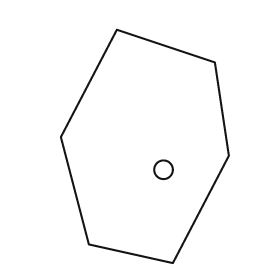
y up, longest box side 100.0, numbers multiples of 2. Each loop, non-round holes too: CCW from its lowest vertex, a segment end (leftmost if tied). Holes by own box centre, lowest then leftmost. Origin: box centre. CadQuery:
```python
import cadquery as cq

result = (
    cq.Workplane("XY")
    .moveTo(12.0, -50.0)
    .lineTo(36.0, -4.0)
    .lineTo(30.0, 36.0)
    .lineTo(-12.0, 50.0)
    .lineTo(-36.0, 4.0)
    .lineTo(-24.0, -42.0)
    .close()
    .moveTo(8.0, -10.0)
    .circle(4.0)
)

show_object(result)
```